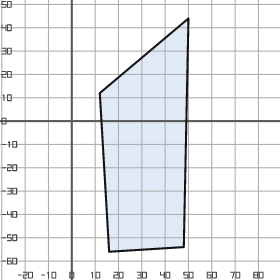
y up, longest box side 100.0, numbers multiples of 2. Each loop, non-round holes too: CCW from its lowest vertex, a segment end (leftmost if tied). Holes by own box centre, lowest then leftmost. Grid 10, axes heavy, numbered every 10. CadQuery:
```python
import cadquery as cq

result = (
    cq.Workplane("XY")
    .moveTo(16.0, -56.0)
    .lineTo(48.0, -54.0)
    .lineTo(50.0, 44.0)
    .lineTo(12.0, 12.0)
    .close()
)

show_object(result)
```